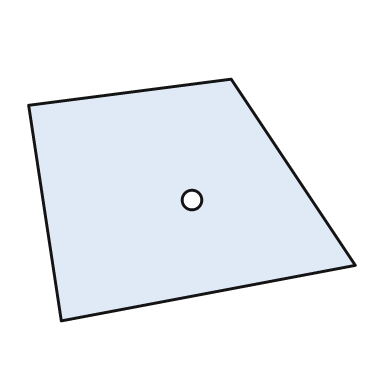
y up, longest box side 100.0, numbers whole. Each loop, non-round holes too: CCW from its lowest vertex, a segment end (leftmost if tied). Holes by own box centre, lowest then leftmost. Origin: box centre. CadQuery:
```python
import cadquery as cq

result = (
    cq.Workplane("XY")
    .moveTo(-40.0, -37.0)
    .lineTo(50.0, -20.0)
    .lineTo(12.0, 37.0)
    .lineTo(-50.0, 29.0)
    .close()
    .moveTo(0.0, 0.0)
    .circle(3.0)
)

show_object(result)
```